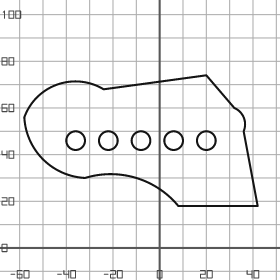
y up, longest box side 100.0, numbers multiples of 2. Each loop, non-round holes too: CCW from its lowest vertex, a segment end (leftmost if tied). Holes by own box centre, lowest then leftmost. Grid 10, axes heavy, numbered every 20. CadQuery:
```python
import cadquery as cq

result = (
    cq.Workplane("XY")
    .moveTo(8.0, 18.0)
    .lineTo(42.0, 18.0)
    .lineTo(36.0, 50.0)
    .threePointArc((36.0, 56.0), (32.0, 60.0))
    .lineTo(20.0, 74.0)
    .lineTo(-24.0, 68.0)
    .threePointArc((-44.0, 70.0), (-58.0, 56.0))
    .threePointArc((-50.0, 38.0), (-32.0, 30.0))
    .threePointArc((-10.0, 30.0), (8.0, 18.0))
    .close()
    .moveTo(-36.0, 46.0)
    .circle(4.0)
    .moveTo(-22.0, 46.0)
    .circle(4.0)
    .moveTo(-8.0, 46.0)
    .circle(4.0)
    .moveTo(6.0, 46.0)
    .circle(4.0)
    .moveTo(20.0, 46.0)
    .circle(4.0)
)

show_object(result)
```